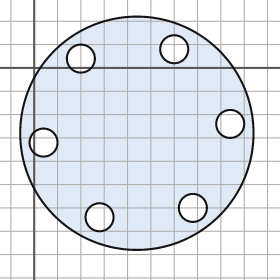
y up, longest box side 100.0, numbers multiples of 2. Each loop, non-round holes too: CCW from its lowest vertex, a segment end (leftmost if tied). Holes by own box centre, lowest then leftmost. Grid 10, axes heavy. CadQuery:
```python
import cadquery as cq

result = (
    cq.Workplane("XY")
    .moveTo(44.0, -28.0)
    .circle(50.0)
    .moveTo(28.0, -64.0)
    .circle(6.0)
    .moveTo(68.0, -60.0)
    .circle(6.0)
    .moveTo(4.0, -32.0)
    .circle(6.0)
    .moveTo(84.0, -24.0)
    .circle(6.0)
    .moveTo(20.0, 4.0)
    .circle(6.0)
    .moveTo(60.0, 8.0)
    .circle(6.0)
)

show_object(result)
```